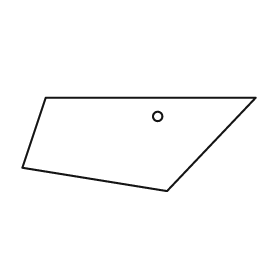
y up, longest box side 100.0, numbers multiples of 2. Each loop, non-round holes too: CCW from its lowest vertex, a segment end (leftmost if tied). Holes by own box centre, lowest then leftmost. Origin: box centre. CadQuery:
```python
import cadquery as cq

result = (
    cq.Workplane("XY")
    .moveTo(12.0, -20.0)
    .lineTo(50.0, 20.0)
    .lineTo(-40.0, 20.0)
    .lineTo(-50.0, -10.0)
    .close()
    .moveTo(8.0, 12.0)
    .circle(2.0)
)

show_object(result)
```